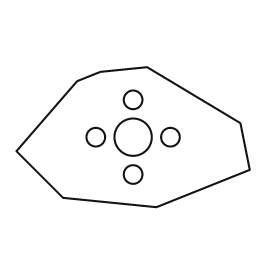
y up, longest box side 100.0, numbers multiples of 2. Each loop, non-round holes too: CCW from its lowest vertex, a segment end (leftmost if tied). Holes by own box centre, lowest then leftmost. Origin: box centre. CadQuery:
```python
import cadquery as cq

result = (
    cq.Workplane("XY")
    .moveTo(10.0, -30.0)
    .lineTo(50.0, -14.0)
    .lineTo(46.0, 6.0)
    .lineTo(6.0, 30.0)
    .lineTo(-14.0, 28.0)
    .lineTo(-24.0, 24.0)
    .lineTo(-50.0, -6.0)
    .lineTo(-30.0, -26.0)
    .close()
    .moveTo(0.0, -16.0)
    .circle(4.0)
    .moveTo(-16.0, 0.0)
    .circle(4.0)
    .moveTo(0.0, 0.0)
    .circle(8.0)
    .moveTo(16.0, 0.0)
    .circle(4.0)
    .moveTo(0.0, 16.0)
    .circle(4.0)
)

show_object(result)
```